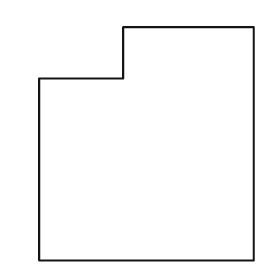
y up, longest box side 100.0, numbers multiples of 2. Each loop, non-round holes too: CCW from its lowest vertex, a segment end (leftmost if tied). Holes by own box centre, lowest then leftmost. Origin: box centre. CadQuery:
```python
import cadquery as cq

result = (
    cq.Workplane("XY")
    .moveTo(-46.0, -50.0)
    .lineTo(46.0, -50.0)
    .lineTo(46.0, 50.0)
    .lineTo(-10.0, 50.0)
    .lineTo(-10.0, 28.0)
    .lineTo(-46.0, 28.0)
    .close()
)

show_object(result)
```